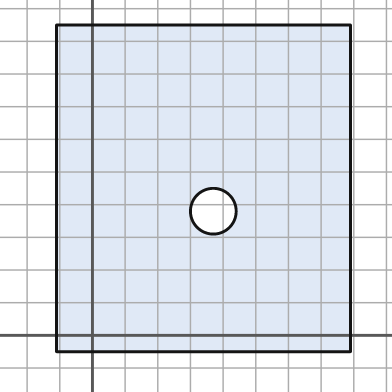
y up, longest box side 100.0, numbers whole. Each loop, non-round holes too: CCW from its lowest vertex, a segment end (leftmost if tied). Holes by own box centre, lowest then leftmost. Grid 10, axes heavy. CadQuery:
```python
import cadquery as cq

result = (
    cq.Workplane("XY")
    .moveTo(-11.0, -5.0)
    .lineTo(79.0, -5.0)
    .lineTo(79.0, 95.0)
    .lineTo(-11.0, 95.0)
    .close()
    .moveTo(37.0, 38.0)
    .circle(7.0)
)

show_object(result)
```